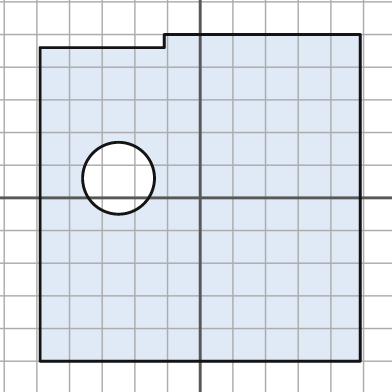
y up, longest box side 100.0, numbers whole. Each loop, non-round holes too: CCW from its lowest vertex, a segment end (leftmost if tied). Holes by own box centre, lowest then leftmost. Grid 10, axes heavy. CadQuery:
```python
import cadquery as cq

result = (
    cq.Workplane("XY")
    .moveTo(-49.0, -50.0)
    .lineTo(49.0, -50.0)
    .lineTo(49.0, 50.0)
    .lineTo(-11.0, 50.0)
    .lineTo(-11.0, 46.0)
    .lineTo(-49.0, 46.0)
    .close()
    .moveTo(-25.0, 6.0)
    .circle(11.0)
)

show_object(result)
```